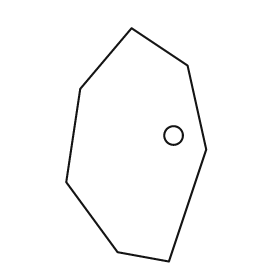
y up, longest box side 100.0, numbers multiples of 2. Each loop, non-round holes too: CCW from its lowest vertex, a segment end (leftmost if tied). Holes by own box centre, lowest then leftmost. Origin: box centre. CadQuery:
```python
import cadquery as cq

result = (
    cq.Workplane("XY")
    .moveTo(14.0, -50.0)
    .lineTo(30.0, -2.0)
    .lineTo(22.0, 34.0)
    .lineTo(-2.0, 50.0)
    .lineTo(-24.0, 24.0)
    .lineTo(-30.0, -16.0)
    .lineTo(-8.0, -46.0)
    .close()
    .moveTo(16.0, 4.0)
    .circle(4.0)
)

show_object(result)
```